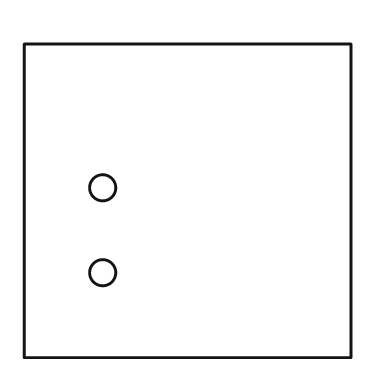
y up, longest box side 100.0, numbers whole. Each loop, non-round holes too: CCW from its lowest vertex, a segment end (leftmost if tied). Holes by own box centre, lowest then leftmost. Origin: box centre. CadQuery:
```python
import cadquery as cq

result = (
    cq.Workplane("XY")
    .moveTo(-50.0, -48.0)
    .lineTo(50.0, -48.0)
    .lineTo(50.0, 48.0)
    .lineTo(-50.0, 48.0)
    .close()
    .moveTo(-26.0, -22.0)
    .circle(4.0)
    .moveTo(-26.0, 4.0)
    .circle(4.0)
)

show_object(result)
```